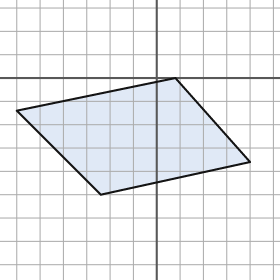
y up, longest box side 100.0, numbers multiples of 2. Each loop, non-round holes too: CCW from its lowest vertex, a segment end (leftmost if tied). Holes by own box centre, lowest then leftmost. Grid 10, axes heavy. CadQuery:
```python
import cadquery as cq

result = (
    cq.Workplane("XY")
    .moveTo(-24.0, -50.0)
    .lineTo(40.0, -36.0)
    .lineTo(8.0, 0.0)
    .lineTo(-60.0, -14.0)
    .close()
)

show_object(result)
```